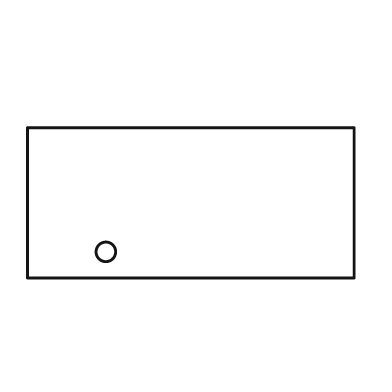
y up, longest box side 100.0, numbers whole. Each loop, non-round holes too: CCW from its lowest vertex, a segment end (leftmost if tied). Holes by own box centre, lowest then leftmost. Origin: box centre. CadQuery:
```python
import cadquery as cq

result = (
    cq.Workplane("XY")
    .moveTo(-50.0, -23.0)
    .lineTo(50.0, -23.0)
    .lineTo(50.0, 23.0)
    .lineTo(-50.0, 23.0)
    .close()
    .moveTo(-26.0, -15.0)
    .circle(3.0)
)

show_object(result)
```